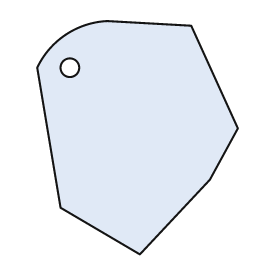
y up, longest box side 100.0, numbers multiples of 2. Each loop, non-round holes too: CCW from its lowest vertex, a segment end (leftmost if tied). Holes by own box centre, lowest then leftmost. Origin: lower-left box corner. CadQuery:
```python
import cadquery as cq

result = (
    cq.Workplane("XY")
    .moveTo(44.0, 0.0)
    .lineTo(74.0, 32.0)
    .lineTo(86.0, 54.0)
    .lineTo(66.0, 98.0)
    .lineTo(30.0, 100.0)
    .threePointArc((12.0, 94.0), (0.0, 80.0))
    .lineTo(10.0, 20.0)
    .close()
    .moveTo(14.0, 80.0)
    .circle(4.0)
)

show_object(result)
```